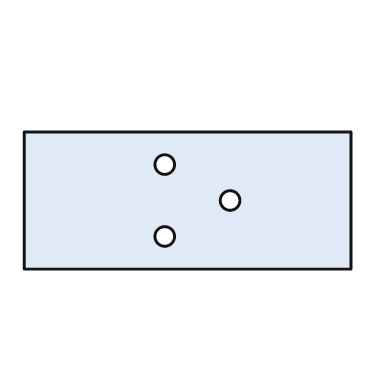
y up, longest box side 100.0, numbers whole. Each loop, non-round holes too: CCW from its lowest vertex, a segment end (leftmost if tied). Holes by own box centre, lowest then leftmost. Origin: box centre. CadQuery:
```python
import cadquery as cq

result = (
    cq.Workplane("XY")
    .moveTo(-50.0, -21.0)
    .lineTo(50.0, -21.0)
    .lineTo(50.0, 21.0)
    .lineTo(-50.0, 21.0)
    .close()
    .moveTo(-7.0, -11.0)
    .circle(3.0)
    .moveTo(13.0, 0.0)
    .circle(3.0)
    .moveTo(-7.0, 11.0)
    .circle(3.0)
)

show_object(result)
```